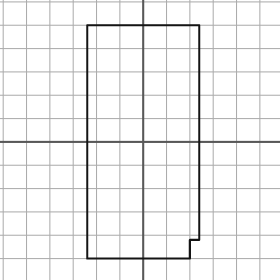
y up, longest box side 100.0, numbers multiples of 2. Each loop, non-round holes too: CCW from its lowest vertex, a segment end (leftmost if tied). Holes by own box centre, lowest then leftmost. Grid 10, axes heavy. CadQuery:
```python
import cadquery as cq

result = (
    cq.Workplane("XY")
    .moveTo(-24.0, -50.0)
    .lineTo(20.0, -50.0)
    .lineTo(20.0, -42.0)
    .lineTo(24.0, -42.0)
    .lineTo(24.0, 50.0)
    .lineTo(-24.0, 50.0)
    .close()
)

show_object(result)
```